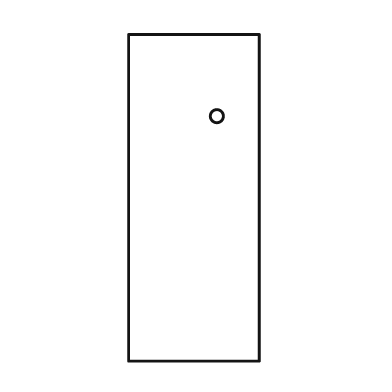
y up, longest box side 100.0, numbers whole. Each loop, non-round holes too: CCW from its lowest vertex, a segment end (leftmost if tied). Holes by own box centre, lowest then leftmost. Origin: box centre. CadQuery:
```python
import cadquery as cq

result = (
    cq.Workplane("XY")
    .moveTo(-20.0, -50.0)
    .lineTo(20.0, -50.0)
    .lineTo(20.0, 50.0)
    .lineTo(-20.0, 50.0)
    .close()
    .moveTo(7.0, 25.0)
    .circle(2.0)
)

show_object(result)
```